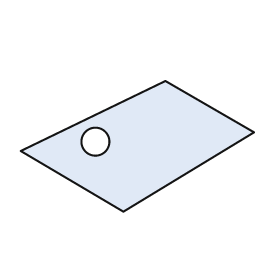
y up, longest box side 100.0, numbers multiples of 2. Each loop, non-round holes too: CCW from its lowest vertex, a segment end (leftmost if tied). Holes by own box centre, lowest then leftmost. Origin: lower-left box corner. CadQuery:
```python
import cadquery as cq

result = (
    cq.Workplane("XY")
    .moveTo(44.0, 0.0)
    .lineTo(100.0, 34.0)
    .lineTo(62.0, 56.0)
    .lineTo(0.0, 26.0)
    .close()
    .moveTo(32.0, 30.0)
    .circle(6.0)
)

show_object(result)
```